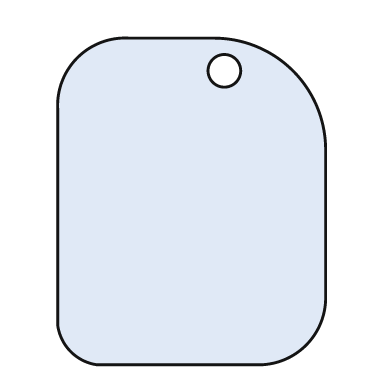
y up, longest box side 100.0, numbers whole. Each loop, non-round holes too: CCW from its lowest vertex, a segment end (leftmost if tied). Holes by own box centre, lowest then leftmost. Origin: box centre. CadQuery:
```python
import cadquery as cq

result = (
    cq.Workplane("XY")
    .moveTo(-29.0, -50.0)
    .lineTo(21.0, -50.0)
    .threePointArc((35.0, -44.0), (41.0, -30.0))
    .lineTo(41.0, 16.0)
    .threePointArc((31.0, 40.0), (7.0, 50.0))
    .lineTo(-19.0, 50.0)
    .threePointArc((-35.0, 44.0), (-41.0, 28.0))
    .lineTo(-41.0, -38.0)
    .threePointArc((-37.0, -46.0), (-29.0, -50.0))
    .close()
    .moveTo(10.0, 40.0)
    .circle(5.0)
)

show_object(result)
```